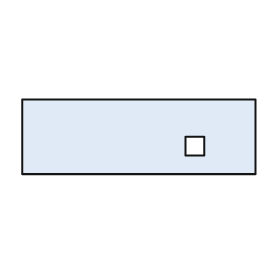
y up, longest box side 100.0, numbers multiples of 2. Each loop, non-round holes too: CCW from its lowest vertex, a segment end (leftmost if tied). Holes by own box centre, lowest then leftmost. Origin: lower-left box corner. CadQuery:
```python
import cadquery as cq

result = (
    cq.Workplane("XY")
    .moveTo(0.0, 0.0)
    .lineTo(100.0, 0.0)
    .lineTo(100.0, 32.0)
    .lineTo(0.0, 32.0)
    .close()
    .moveTo(70.0, 8.0)
    .lineTo(78.0, 8.0)
    .lineTo(78.0, 16.0)
    .lineTo(70.0, 16.0)
    .close()
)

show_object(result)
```